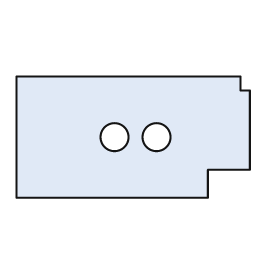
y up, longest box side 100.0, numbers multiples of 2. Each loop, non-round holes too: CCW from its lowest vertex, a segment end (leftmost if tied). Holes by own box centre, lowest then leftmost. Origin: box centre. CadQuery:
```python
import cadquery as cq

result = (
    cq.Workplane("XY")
    .moveTo(-50.0, -26.0)
    .lineTo(32.0, -26.0)
    .lineTo(32.0, -14.0)
    .lineTo(50.0, -14.0)
    .lineTo(50.0, 20.0)
    .lineTo(46.0, 20.0)
    .lineTo(46.0, 26.0)
    .lineTo(-50.0, 26.0)
    .close()
    .moveTo(-8.0, 0.0)
    .circle(6.0)
    .moveTo(10.0, 0.0)
    .circle(6.0)
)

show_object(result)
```